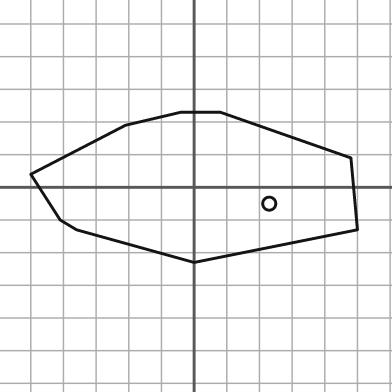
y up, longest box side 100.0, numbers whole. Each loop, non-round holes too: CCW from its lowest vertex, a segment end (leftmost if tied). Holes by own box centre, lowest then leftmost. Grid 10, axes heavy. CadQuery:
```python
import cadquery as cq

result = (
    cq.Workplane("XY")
    .moveTo(0.0, -23.0)
    .lineTo(50.0, -13.0)
    .lineTo(48.0, 9.0)
    .lineTo(8.0, 23.0)
    .lineTo(-4.0, 23.0)
    .lineTo(-21.0, 19.0)
    .lineTo(-50.0, 4.0)
    .lineTo(-41.0, -10.0)
    .lineTo(-36.0, -13.0)
    .close()
    .moveTo(23.0, -5.0)
    .circle(2.0)
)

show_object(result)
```